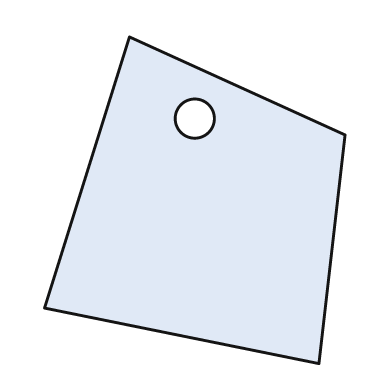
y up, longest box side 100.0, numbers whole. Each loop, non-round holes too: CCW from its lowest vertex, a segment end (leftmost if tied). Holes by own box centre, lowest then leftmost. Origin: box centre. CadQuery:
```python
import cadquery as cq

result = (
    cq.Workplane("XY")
    .moveTo(38.0, -50.0)
    .lineTo(46.0, 20.0)
    .lineTo(-20.0, 50.0)
    .lineTo(-46.0, -33.0)
    .close()
    .moveTo(0.0, 25.0)
    .circle(6.0)
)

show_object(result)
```